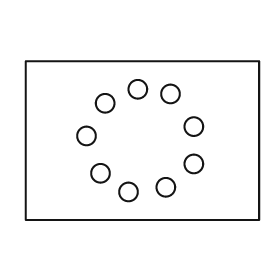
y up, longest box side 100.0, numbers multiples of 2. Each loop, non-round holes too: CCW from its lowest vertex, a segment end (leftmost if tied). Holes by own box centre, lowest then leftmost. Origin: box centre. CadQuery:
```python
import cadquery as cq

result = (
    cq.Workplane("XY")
    .moveTo(-50.0, -34.0)
    .lineTo(50.0, -34.0)
    .lineTo(50.0, 34.0)
    .lineTo(-50.0, 34.0)
    .close()
    .moveTo(-6.0, -22.0)
    .circle(4.0)
    .moveTo(10.0, -20.0)
    .circle(4.0)
    .moveTo(-18.0, -14.0)
    .circle(4.0)
    .moveTo(22.0, -10.0)
    .circle(4.0)
    .moveTo(-24.0, 2.0)
    .circle(4.0)
    .moveTo(22.0, 6.0)
    .circle(4.0)
    .moveTo(-16.0, 16.0)
    .circle(4.0)
    .moveTo(12.0, 20.0)
    .circle(4.0)
    .moveTo(-2.0, 22.0)
    .circle(4.0)
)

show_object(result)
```